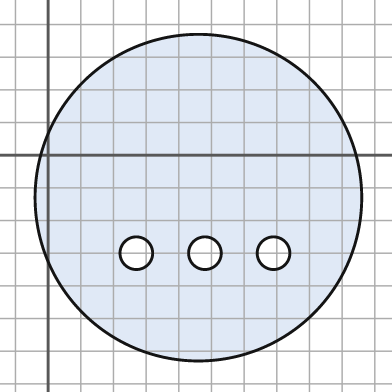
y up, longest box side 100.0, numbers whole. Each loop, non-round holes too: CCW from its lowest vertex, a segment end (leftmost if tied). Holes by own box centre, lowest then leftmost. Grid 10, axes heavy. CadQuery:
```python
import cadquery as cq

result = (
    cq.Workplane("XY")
    .moveTo(46.0, -13.0)
    .circle(50.0)
    .moveTo(27.0, -30.0)
    .circle(5.0)
    .moveTo(48.0, -30.0)
    .circle(5.0)
    .moveTo(69.0, -30.0)
    .circle(5.0)
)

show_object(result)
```